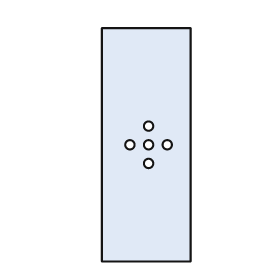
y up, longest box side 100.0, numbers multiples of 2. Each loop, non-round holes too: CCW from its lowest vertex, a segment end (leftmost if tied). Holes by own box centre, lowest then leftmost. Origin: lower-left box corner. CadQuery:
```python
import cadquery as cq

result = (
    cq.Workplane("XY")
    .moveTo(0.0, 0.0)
    .lineTo(38.0, 0.0)
    .lineTo(38.0, 100.0)
    .lineTo(0.0, 100.0)
    .close()
    .moveTo(20.0, 42.0)
    .circle(2.0)
    .moveTo(12.0, 50.0)
    .circle(2.0)
    .moveTo(20.0, 50.0)
    .circle(2.0)
    .moveTo(28.0, 50.0)
    .circle(2.0)
    .moveTo(20.0, 58.0)
    .circle(2.0)
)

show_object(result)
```